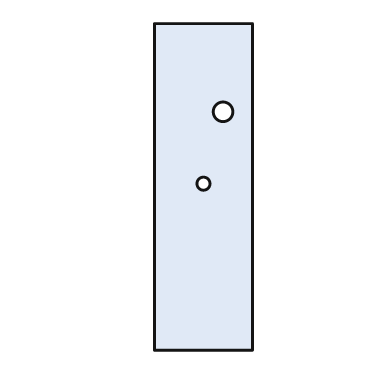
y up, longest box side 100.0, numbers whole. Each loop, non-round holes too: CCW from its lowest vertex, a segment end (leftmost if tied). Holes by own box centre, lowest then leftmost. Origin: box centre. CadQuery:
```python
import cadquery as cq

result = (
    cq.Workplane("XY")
    .moveTo(-15.0, -50.0)
    .lineTo(15.0, -50.0)
    .lineTo(15.0, 50.0)
    .lineTo(-15.0, 50.0)
    .close()
    .moveTo(0.0, 1.0)
    .circle(2.0)
    .moveTo(6.0, 23.0)
    .circle(3.0)
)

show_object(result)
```